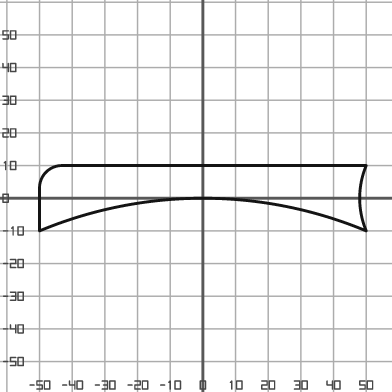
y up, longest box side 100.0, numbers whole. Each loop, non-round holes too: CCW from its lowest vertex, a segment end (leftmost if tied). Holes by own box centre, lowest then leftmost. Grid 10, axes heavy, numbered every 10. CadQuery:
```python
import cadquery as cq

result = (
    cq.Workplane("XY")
    .moveTo(-50.0, -10.0)
    .threePointArc((0.0, 0.0), (50.0, -10.0))
    .threePointArc((48.0, 0.0), (50.0, 10.0))
    .lineTo(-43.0, 10.0)
    .threePointArc((-48.0, 8.0), (-50.0, 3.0))
    .close()
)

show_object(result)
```